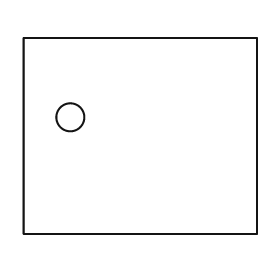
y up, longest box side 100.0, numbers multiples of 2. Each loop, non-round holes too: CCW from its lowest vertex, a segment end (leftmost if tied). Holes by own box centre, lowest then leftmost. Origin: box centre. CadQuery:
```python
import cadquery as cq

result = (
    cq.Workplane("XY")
    .moveTo(-50.0, -42.0)
    .lineTo(50.0, -42.0)
    .lineTo(50.0, 42.0)
    .lineTo(-50.0, 42.0)
    .close()
    .moveTo(-30.0, 8.0)
    .circle(6.0)
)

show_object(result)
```